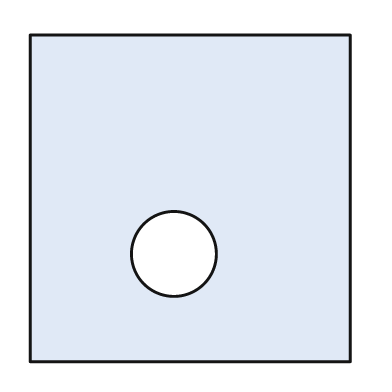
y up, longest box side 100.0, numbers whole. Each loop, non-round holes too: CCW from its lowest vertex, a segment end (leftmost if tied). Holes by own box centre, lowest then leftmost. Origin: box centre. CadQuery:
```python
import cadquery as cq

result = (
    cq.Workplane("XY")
    .moveTo(-49.0, -50.0)
    .lineTo(49.0, -50.0)
    .lineTo(49.0, 50.0)
    .lineTo(-49.0, 50.0)
    .close()
    .moveTo(-5.0, -17.0)
    .circle(13.0)
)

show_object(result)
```